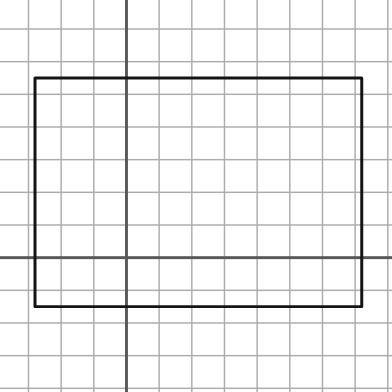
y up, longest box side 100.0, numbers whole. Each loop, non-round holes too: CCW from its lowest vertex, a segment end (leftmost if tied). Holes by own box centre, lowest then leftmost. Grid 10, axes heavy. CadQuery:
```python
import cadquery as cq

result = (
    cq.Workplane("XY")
    .moveTo(-28.0, -15.0)
    .lineTo(72.0, -15.0)
    .lineTo(72.0, 55.0)
    .lineTo(-28.0, 55.0)
    .close()
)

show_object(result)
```